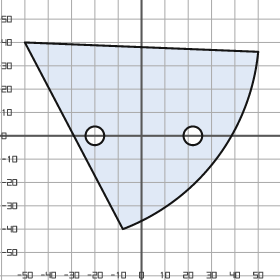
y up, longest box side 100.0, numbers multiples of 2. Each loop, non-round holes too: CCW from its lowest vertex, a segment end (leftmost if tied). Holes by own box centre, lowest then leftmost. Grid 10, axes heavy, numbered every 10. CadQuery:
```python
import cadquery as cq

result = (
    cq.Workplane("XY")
    .moveTo(-8.0, -40.0)
    .threePointArc((32.0, -10.0), (50.0, 36.0))
    .lineTo(-50.0, 40.0)
    .close()
    .moveTo(-20.0, 0.0)
    .circle(4.0)
    .moveTo(22.0, 0.0)
    .circle(4.0)
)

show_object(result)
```